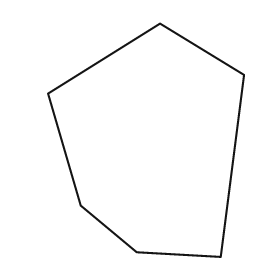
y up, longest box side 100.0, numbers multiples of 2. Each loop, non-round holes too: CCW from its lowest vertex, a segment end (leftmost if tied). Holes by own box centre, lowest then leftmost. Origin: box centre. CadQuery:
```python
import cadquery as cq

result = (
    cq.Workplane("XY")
    .moveTo(32.0, -50.0)
    .lineTo(42.0, 28.0)
    .lineTo(6.0, 50.0)
    .lineTo(-42.0, 20.0)
    .lineTo(-28.0, -28.0)
    .lineTo(-4.0, -48.0)
    .close()
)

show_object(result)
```